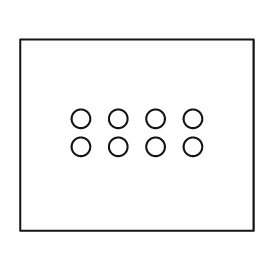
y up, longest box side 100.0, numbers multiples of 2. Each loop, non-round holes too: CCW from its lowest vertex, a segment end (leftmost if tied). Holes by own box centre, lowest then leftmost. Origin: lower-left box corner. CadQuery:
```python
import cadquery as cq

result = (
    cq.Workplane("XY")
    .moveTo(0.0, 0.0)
    .lineTo(100.0, 0.0)
    .lineTo(100.0, 82.0)
    .lineTo(0.0, 82.0)
    .close()
    .moveTo(26.0, 36.0)
    .circle(4.0)
    .moveTo(42.0, 36.0)
    .circle(4.0)
    .moveTo(58.0, 36.0)
    .circle(4.0)
    .moveTo(74.0, 36.0)
    .circle(4.0)
    .moveTo(26.0, 48.0)
    .circle(4.0)
    .moveTo(42.0, 48.0)
    .circle(4.0)
    .moveTo(58.0, 48.0)
    .circle(4.0)
    .moveTo(74.0, 48.0)
    .circle(4.0)
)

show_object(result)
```